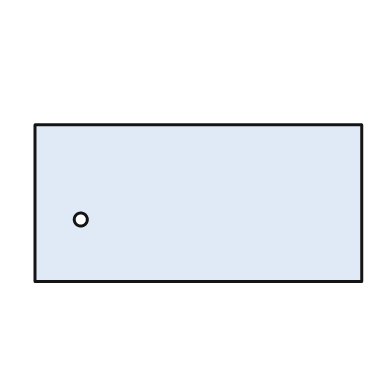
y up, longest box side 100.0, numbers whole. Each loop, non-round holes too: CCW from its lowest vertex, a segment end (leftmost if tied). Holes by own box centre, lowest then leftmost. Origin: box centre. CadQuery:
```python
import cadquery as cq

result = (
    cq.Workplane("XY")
    .moveTo(-50.0, -24.0)
    .lineTo(50.0, -24.0)
    .lineTo(50.0, 24.0)
    .lineTo(-50.0, 24.0)
    .close()
    .moveTo(-36.0, -5.0)
    .circle(2.0)
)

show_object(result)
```